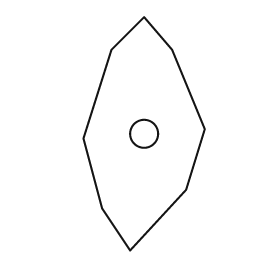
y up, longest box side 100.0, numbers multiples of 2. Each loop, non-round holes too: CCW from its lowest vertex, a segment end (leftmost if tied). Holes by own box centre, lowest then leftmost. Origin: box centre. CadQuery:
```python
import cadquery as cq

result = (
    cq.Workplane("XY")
    .moveTo(-6.0, -50.0)
    .lineTo(18.0, -24.0)
    .lineTo(26.0, 2.0)
    .lineTo(12.0, 36.0)
    .lineTo(0.0, 50.0)
    .lineTo(-14.0, 36.0)
    .lineTo(-26.0, -2.0)
    .lineTo(-18.0, -32.0)
    .close()
    .moveTo(0.0, 0.0)
    .circle(6.0)
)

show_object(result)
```